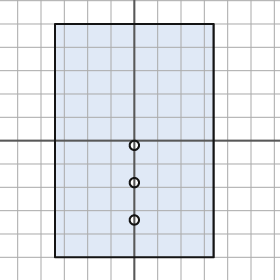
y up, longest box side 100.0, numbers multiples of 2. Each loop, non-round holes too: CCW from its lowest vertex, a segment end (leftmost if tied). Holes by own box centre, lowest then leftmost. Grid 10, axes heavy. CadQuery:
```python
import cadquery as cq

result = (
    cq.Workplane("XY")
    .moveTo(-34.0, -50.0)
    .lineTo(34.0, -50.0)
    .lineTo(34.0, 50.0)
    .lineTo(-34.0, 50.0)
    .close()
    .moveTo(0.0, -34.0)
    .circle(2.0)
    .moveTo(0.0, -18.0)
    .circle(2.0)
    .moveTo(0.0, -2.0)
    .circle(2.0)
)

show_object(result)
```